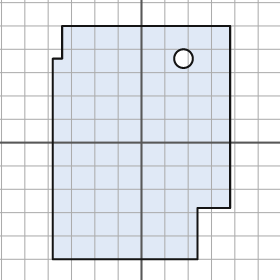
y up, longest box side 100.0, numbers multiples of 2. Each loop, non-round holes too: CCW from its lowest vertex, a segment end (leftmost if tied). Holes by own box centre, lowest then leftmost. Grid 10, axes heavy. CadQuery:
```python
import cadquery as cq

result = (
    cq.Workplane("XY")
    .moveTo(-38.0, -50.0)
    .lineTo(24.0, -50.0)
    .lineTo(24.0, -28.0)
    .lineTo(38.0, -28.0)
    .lineTo(38.0, 50.0)
    .lineTo(-34.0, 50.0)
    .lineTo(-34.0, 36.0)
    .lineTo(-38.0, 36.0)
    .close()
    .moveTo(18.0, 36.0)
    .circle(4.0)
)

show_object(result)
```